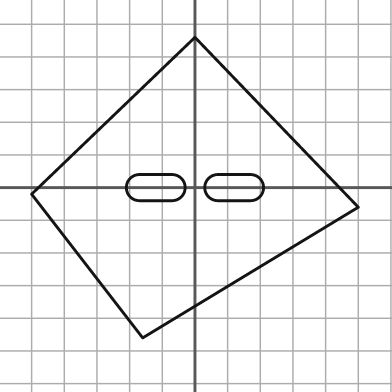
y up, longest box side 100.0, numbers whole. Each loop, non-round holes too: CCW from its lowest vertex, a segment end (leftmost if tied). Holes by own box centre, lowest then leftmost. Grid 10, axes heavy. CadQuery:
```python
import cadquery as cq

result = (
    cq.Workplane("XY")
    .moveTo(-16.0, -46.0)
    .lineTo(50.0, -6.0)
    .lineTo(0.0, 46.0)
    .lineTo(-50.0, -2.0)
    .close()
    .moveTo(-17.0, -4.0)
    .lineTo(-7.0, -4.0)
    .threePointArc((-3.0, 0.0), (-7.0, 4.0))
    .lineTo(-17.0, 4.0)
    .threePointArc((-21.0, 0.0), (-17.0, -4.0))
    .close()
    .moveTo(7.0, -4.0)
    .lineTo(17.0, -4.0)
    .threePointArc((21.0, 0.0), (17.0, 4.0))
    .lineTo(7.0, 4.0)
    .threePointArc((3.0, 0.0), (7.0, -4.0))
    .close()
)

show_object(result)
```